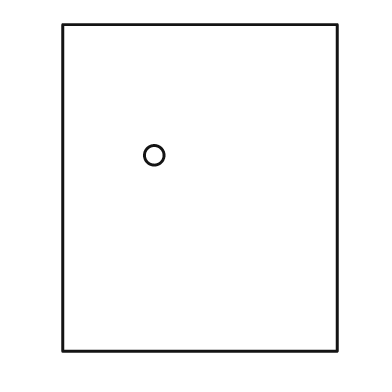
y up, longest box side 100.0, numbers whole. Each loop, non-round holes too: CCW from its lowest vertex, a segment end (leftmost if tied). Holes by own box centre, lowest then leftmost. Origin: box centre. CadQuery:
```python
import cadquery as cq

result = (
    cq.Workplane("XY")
    .moveTo(-42.0, -50.0)
    .lineTo(42.0, -50.0)
    .lineTo(42.0, 50.0)
    .lineTo(-42.0, 50.0)
    .close()
    .moveTo(-14.0, 10.0)
    .circle(3.0)
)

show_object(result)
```